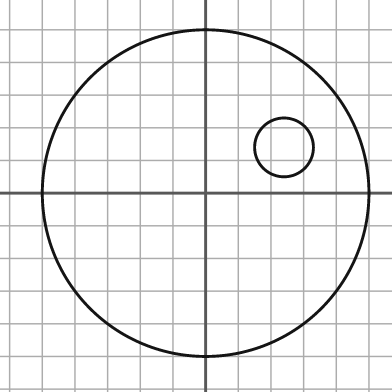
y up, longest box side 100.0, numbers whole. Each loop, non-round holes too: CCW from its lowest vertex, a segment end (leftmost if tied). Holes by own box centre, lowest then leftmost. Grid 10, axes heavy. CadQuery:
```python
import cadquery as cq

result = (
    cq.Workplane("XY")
    .moveTo(0.0, 0.0)
    .circle(50.0)
    .moveTo(24.0, 14.0)
    .circle(9.0)
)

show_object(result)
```